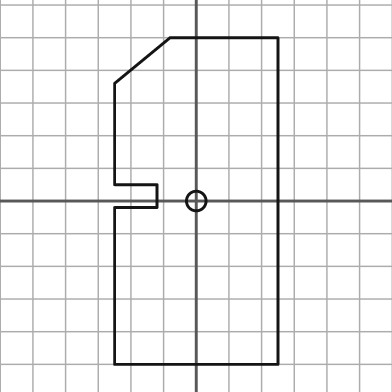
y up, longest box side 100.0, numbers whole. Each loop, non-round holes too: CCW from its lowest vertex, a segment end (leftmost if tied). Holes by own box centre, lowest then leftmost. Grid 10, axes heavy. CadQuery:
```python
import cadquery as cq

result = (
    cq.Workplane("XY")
    .moveTo(-25.0, -50.0)
    .lineTo(25.0, -50.0)
    .lineTo(25.0, 50.0)
    .lineTo(-8.0, 50.0)
    .lineTo(-25.0, 36.0)
    .lineTo(-25.0, 5.0)
    .lineTo(-12.0, 5.0)
    .lineTo(-12.0, -2.0)
    .lineTo(-25.0, -2.0)
    .close()
    .moveTo(0.0, 0.0)
    .circle(3.0)
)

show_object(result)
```